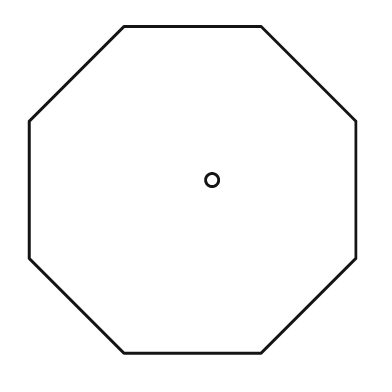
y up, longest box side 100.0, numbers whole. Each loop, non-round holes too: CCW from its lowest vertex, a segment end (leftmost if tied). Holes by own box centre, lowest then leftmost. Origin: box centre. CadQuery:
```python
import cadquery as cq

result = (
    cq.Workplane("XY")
    .moveTo(-21.0, -50.0)
    .lineTo(21.0, -50.0)
    .lineTo(50.0, -21.0)
    .lineTo(50.0, 21.0)
    .lineTo(21.0, 50.0)
    .lineTo(-21.0, 50.0)
    .lineTo(-50.0, 21.0)
    .lineTo(-50.0, -21.0)
    .close()
    .moveTo(6.0, 3.0)
    .circle(2.0)
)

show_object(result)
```